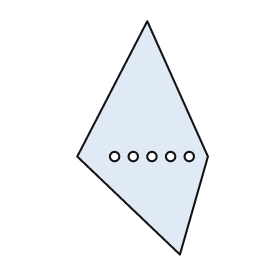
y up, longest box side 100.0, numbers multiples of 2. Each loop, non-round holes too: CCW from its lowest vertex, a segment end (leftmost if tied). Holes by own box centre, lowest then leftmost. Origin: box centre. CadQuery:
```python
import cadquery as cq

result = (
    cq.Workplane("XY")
    .moveTo(16.0, -50.0)
    .lineTo(28.0, -8.0)
    .lineTo(2.0, 50.0)
    .lineTo(-28.0, -8.0)
    .close()
    .moveTo(-12.0, -8.0)
    .circle(2.0)
    .moveTo(-4.0, -8.0)
    .circle(2.0)
    .moveTo(4.0, -8.0)
    .circle(2.0)
    .moveTo(12.0, -8.0)
    .circle(2.0)
    .moveTo(20.0, -8.0)
    .circle(2.0)
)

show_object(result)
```